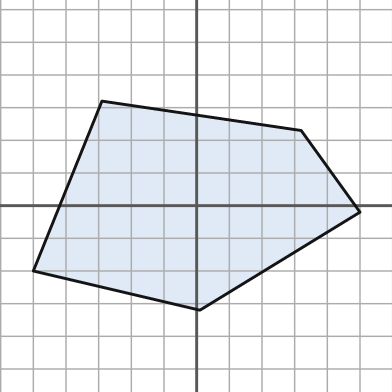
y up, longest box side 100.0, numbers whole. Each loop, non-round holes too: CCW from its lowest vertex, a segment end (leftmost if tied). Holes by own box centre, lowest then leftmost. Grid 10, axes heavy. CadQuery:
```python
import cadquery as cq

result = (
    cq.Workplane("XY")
    .moveTo(1.0, -32.0)
    .lineTo(50.0, -2.0)
    .lineTo(32.0, 23.0)
    .lineTo(-29.0, 32.0)
    .lineTo(-50.0, -20.0)
    .close()
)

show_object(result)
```